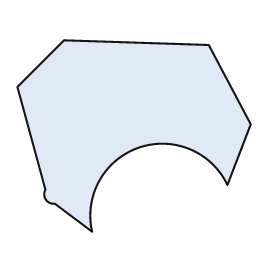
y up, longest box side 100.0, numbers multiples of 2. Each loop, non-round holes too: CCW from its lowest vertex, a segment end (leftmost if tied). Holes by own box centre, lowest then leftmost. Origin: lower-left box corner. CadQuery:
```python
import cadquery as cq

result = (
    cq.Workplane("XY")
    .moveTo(32.0, 0.0)
    .threePointArc((52.0, 36.0), (90.0, 20.0))
    .lineTo(100.0, 46.0)
    .lineTo(82.0, 80.0)
    .lineTo(20.0, 82.0)
    .lineTo(0.0, 62.0)
    .lineTo(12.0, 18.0)
    .threePointArc((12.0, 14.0), (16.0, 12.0))
    .close()
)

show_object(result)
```